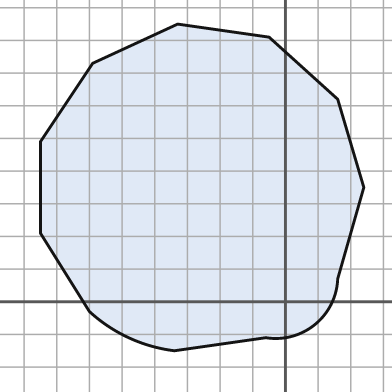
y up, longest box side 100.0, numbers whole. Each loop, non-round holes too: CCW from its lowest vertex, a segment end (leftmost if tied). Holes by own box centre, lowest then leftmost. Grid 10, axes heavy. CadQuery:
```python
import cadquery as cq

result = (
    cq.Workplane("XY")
    .moveTo(-34.0, -15.0)
    .lineTo(-6.0, -11.0)
    .threePointArc((9.0, -7.0), (16.0, 7.0))
    .lineTo(24.0, 35.0)
    .lineTo(16.0, 62.0)
    .lineTo(-5.0, 81.0)
    .lineTo(-33.0, 85.0)
    .lineTo(-59.0, 73.0)
    .lineTo(-75.0, 49.0)
    .lineTo(-75.0, 21.0)
    .lineTo(-60.0, -3.0)
    .threePointArc((-48.0, -11.0), (-34.0, -15.0))
    .close()
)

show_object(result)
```